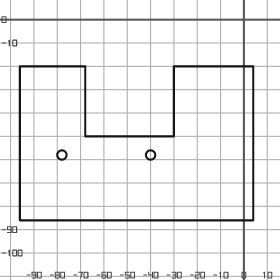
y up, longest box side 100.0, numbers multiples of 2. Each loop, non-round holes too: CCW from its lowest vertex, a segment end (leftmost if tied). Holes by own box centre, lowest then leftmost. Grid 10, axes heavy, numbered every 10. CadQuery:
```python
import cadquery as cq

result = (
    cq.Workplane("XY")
    .moveTo(-96.0, -86.0)
    .lineTo(4.0, -86.0)
    .lineTo(4.0, -20.0)
    .lineTo(-30.0, -20.0)
    .lineTo(-30.0, -50.0)
    .lineTo(-68.0, -50.0)
    .lineTo(-68.0, -20.0)
    .lineTo(-96.0, -20.0)
    .close()
    .moveTo(-78.0, -58.0)
    .circle(2.0)
    .moveTo(-40.0, -58.0)
    .circle(2.0)
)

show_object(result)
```